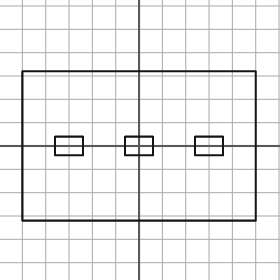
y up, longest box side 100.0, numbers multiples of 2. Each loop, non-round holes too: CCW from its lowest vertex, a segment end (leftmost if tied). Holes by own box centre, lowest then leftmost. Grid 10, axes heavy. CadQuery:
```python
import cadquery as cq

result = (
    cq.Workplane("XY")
    .moveTo(-50.0, -32.0)
    .lineTo(50.0, -32.0)
    .lineTo(50.0, 32.0)
    .lineTo(-50.0, 32.0)
    .close()
    .moveTo(-36.0, -4.0)
    .lineTo(-24.0, -4.0)
    .lineTo(-24.0, 4.0)
    .lineTo(-36.0, 4.0)
    .close()
    .moveTo(-6.0, -4.0)
    .lineTo(6.0, -4.0)
    .lineTo(6.0, 4.0)
    .lineTo(-6.0, 4.0)
    .close()
    .moveTo(24.0, -4.0)
    .lineTo(36.0, -4.0)
    .lineTo(36.0, 4.0)
    .lineTo(24.0, 4.0)
    .close()
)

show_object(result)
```